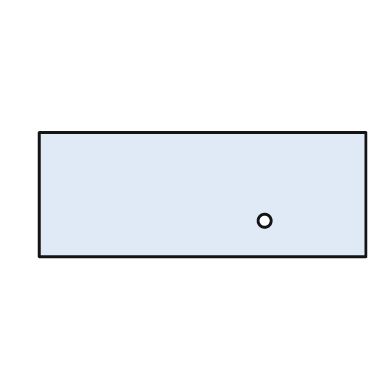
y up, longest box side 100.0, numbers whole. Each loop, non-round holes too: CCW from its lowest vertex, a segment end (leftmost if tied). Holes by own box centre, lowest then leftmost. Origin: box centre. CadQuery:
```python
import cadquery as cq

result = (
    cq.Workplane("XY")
    .moveTo(-50.0, -19.0)
    .lineTo(50.0, -19.0)
    .lineTo(50.0, 19.0)
    .lineTo(-50.0, 19.0)
    .close()
    .moveTo(19.0, -8.0)
    .circle(2.0)
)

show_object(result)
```